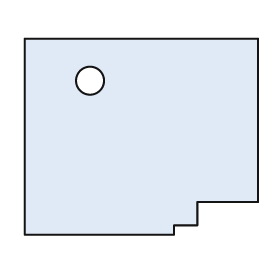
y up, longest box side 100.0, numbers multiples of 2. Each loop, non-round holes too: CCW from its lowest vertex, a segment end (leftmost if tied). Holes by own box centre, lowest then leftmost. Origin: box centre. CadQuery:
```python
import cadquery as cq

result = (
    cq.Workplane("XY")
    .moveTo(-50.0, -42.0)
    .lineTo(14.0, -42.0)
    .lineTo(14.0, -38.0)
    .lineTo(24.0, -38.0)
    .lineTo(24.0, -28.0)
    .lineTo(50.0, -28.0)
    .lineTo(50.0, 42.0)
    .lineTo(-50.0, 42.0)
    .close()
    .moveTo(-22.0, 24.0)
    .circle(6.0)
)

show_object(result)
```